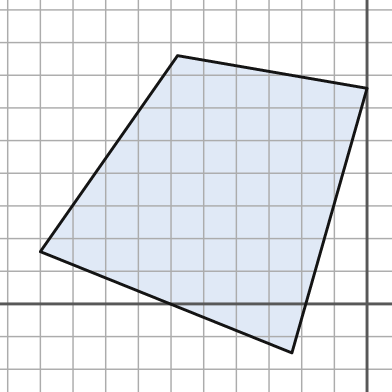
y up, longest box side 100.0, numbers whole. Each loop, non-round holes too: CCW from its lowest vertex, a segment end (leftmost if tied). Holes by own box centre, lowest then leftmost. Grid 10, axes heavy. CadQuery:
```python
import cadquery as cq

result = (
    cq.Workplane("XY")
    .moveTo(-23.0, -15.0)
    .lineTo(0.0, 66.0)
    .lineTo(-58.0, 76.0)
    .lineTo(-100.0, 16.0)
    .close()
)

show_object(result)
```